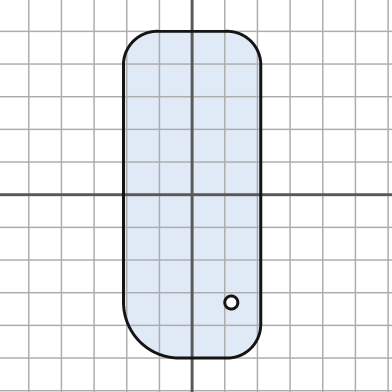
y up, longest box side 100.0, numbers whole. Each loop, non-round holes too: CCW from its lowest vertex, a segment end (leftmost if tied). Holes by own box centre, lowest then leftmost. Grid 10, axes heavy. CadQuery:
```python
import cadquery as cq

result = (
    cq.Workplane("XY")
    .moveTo(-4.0, -50.0)
    .lineTo(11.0, -50.0)
    .threePointArc((18.0, -47.0), (21.0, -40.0))
    .lineTo(21.0, 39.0)
    .threePointArc((18.0, 47.0), (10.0, 50.0))
    .lineTo(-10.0, 50.0)
    .threePointArc((-18.0, 47.0), (-21.0, 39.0))
    .lineTo(-21.0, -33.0)
    .threePointArc((-16.0, -45.0), (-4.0, -50.0))
    .close()
    .moveTo(12.0, -33.0)
    .circle(2.0)
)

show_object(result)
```